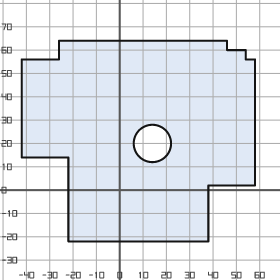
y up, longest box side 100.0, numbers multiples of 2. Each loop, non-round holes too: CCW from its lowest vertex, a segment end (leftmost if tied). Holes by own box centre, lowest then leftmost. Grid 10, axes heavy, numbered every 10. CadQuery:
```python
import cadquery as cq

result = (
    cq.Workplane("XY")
    .moveTo(-22.0, -22.0)
    .lineTo(38.0, -22.0)
    .lineTo(38.0, 2.0)
    .lineTo(58.0, 2.0)
    .lineTo(58.0, 56.0)
    .lineTo(54.0, 56.0)
    .lineTo(54.0, 60.0)
    .lineTo(46.0, 60.0)
    .lineTo(46.0, 64.0)
    .lineTo(-26.0, 64.0)
    .lineTo(-26.0, 56.0)
    .lineTo(-42.0, 56.0)
    .lineTo(-42.0, 14.0)
    .lineTo(-22.0, 14.0)
    .close()
    .moveTo(14.0, 20.0)
    .circle(8.0)
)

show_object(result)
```